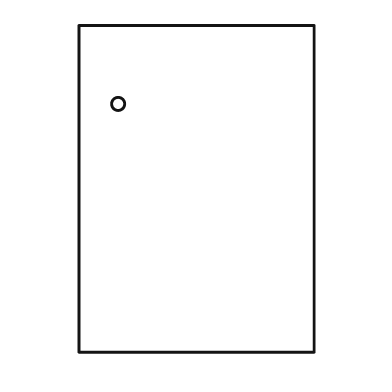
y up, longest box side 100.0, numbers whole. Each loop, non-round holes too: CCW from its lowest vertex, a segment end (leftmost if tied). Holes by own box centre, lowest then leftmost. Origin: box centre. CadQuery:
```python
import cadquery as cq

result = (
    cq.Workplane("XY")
    .moveTo(-36.0, -50.0)
    .lineTo(36.0, -50.0)
    .lineTo(36.0, 50.0)
    .lineTo(-36.0, 50.0)
    .close()
    .moveTo(-24.0, 26.0)
    .circle(2.0)
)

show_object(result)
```